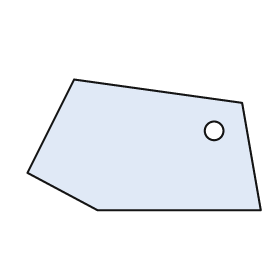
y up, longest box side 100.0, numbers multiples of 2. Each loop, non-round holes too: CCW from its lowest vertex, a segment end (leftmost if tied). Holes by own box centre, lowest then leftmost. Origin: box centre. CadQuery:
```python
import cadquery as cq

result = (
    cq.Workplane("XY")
    .moveTo(-20.0, -28.0)
    .lineTo(50.0, -28.0)
    .lineTo(42.0, 18.0)
    .lineTo(-30.0, 28.0)
    .lineTo(-50.0, -12.0)
    .close()
    .moveTo(30.0, 6.0)
    .circle(4.0)
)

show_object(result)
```